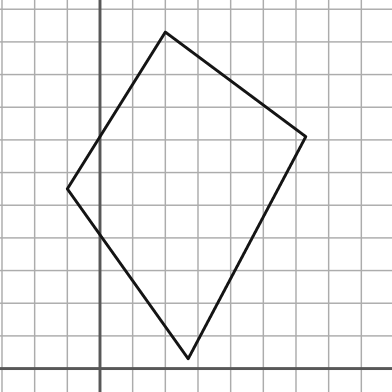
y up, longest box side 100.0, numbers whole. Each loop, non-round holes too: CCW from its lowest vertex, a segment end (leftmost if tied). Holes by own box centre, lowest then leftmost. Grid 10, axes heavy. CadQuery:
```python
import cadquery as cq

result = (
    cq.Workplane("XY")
    .moveTo(27.0, 3.0)
    .lineTo(63.0, 71.0)
    .lineTo(20.0, 103.0)
    .lineTo(-10.0, 55.0)
    .close()
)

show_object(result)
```